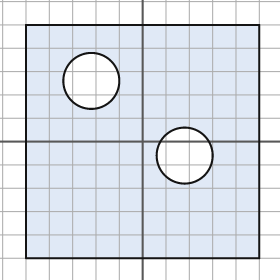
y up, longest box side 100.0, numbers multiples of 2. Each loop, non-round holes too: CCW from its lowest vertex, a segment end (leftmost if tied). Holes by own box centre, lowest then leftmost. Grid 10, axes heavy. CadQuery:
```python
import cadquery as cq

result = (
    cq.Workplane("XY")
    .moveTo(-50.0, -50.0)
    .lineTo(50.0, -50.0)
    .lineTo(50.0, 50.0)
    .lineTo(-50.0, 50.0)
    .close()
    .moveTo(18.0, -6.0)
    .circle(12.0)
    .moveTo(-22.0, 26.0)
    .circle(12.0)
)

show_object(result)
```